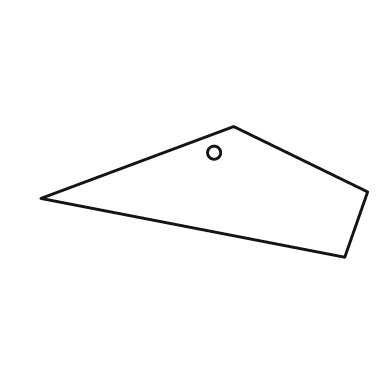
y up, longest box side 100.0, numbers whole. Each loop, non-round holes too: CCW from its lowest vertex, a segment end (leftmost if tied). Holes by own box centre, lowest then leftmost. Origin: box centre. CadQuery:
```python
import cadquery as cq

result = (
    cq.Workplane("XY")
    .moveTo(43.0, -20.0)
    .lineTo(50.0, 0.0)
    .lineTo(9.0, 20.0)
    .lineTo(-50.0, -2.0)
    .close()
    .moveTo(3.0, 12.0)
    .circle(2.0)
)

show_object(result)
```